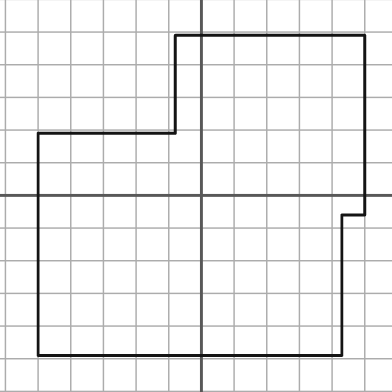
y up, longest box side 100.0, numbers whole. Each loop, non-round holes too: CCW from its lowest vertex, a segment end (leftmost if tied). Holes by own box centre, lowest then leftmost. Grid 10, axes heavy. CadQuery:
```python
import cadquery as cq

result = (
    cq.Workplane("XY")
    .moveTo(-50.0, -49.0)
    .lineTo(43.0, -49.0)
    .lineTo(43.0, -6.0)
    .lineTo(50.0, -6.0)
    .lineTo(50.0, 49.0)
    .lineTo(-8.0, 49.0)
    .lineTo(-8.0, 19.0)
    .lineTo(-50.0, 19.0)
    .close()
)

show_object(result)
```